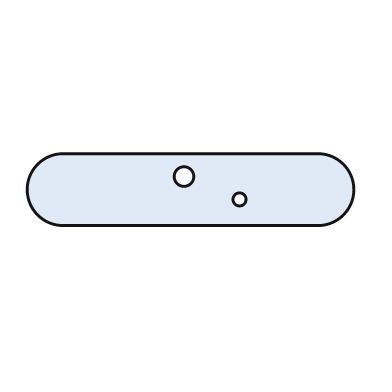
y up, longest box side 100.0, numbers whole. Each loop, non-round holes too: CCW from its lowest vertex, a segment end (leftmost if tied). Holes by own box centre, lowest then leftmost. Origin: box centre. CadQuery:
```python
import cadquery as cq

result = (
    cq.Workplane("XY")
    .moveTo(-39.0, -11.0)
    .lineTo(39.0, -11.0)
    .threePointArc((50.0, 0.0), (39.0, 11.0))
    .lineTo(-39.0, 11.0)
    .threePointArc((-50.0, 0.0), (-39.0, -11.0))
    .close()
    .moveTo(15.0, -3.0)
    .circle(2.0)
    .moveTo(-2.0, 4.0)
    .circle(3.0)
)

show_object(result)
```